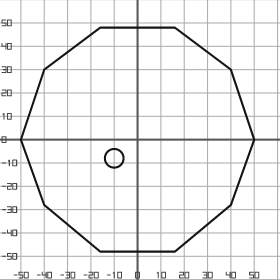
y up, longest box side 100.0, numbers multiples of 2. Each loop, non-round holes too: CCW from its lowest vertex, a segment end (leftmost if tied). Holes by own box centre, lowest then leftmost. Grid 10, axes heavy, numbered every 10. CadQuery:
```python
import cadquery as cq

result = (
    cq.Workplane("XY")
    .moveTo(-16.0, -48.0)
    .lineTo(16.0, -48.0)
    .lineTo(40.0, -28.0)
    .lineTo(50.0, 0.0)
    .lineTo(40.0, 30.0)
    .lineTo(16.0, 48.0)
    .lineTo(-16.0, 48.0)
    .lineTo(-40.0, 30.0)
    .lineTo(-50.0, 0.0)
    .lineTo(-40.0, -28.0)
    .close()
    .moveTo(-10.0, -8.0)
    .circle(4.0)
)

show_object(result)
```